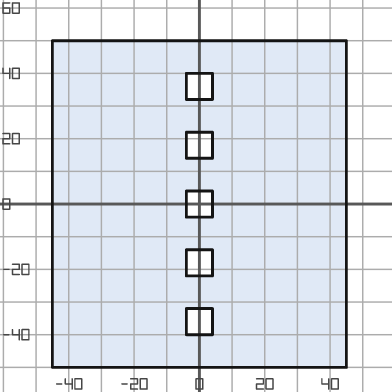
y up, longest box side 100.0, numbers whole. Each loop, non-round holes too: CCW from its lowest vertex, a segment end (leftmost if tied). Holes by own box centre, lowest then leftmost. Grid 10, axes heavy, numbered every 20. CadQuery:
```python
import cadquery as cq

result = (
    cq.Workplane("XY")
    .moveTo(-45.0, -50.0)
    .lineTo(45.0, -50.0)
    .lineTo(45.0, 50.0)
    .lineTo(-45.0, 50.0)
    .close()
    .moveTo(-4.0, -40.0)
    .lineTo(4.0, -40.0)
    .lineTo(4.0, -32.0)
    .lineTo(-4.0, -32.0)
    .close()
    .moveTo(-4.0, -22.0)
    .lineTo(4.0, -22.0)
    .lineTo(4.0, -14.0)
    .lineTo(-4.0, -14.0)
    .close()
    .moveTo(-4.0, -4.0)
    .lineTo(4.0, -4.0)
    .lineTo(4.0, 4.0)
    .lineTo(-4.0, 4.0)
    .close()
    .moveTo(-4.0, 14.0)
    .lineTo(4.0, 14.0)
    .lineTo(4.0, 22.0)
    .lineTo(-4.0, 22.0)
    .close()
    .moveTo(-4.0, 32.0)
    .lineTo(4.0, 32.0)
    .lineTo(4.0, 40.0)
    .lineTo(-4.0, 40.0)
    .close()
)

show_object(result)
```